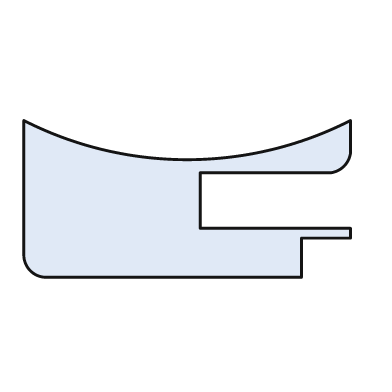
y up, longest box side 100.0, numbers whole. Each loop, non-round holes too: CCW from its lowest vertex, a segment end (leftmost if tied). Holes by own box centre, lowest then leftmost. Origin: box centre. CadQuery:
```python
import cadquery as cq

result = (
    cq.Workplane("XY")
    .moveTo(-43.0, -24.0)
    .lineTo(35.0, -24.0)
    .lineTo(35.0, -12.0)
    .lineTo(50.0, -12.0)
    .lineTo(50.0, -9.0)
    .lineTo(4.0, -9.0)
    .lineTo(4.0, 8.0)
    .lineTo(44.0, 8.0)
    .threePointArc((48.0, 10.0), (50.0, 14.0))
    .lineTo(50.0, 24.0)
    .threePointArc((0.0, 12.0), (-50.0, 24.0))
    .lineTo(-50.0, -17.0)
    .threePointArc((-48.0, -22.0), (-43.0, -24.0))
    .close()
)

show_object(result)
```